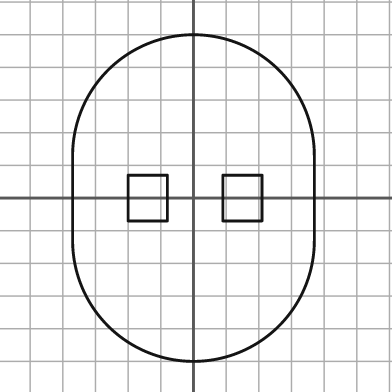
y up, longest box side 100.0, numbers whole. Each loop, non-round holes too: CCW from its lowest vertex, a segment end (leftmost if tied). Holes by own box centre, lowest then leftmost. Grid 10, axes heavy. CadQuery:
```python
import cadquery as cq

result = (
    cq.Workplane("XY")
    .moveTo(-37.0, -13.0)
    .threePointArc((0.0, -50.0), (37.0, -13.0))
    .lineTo(37.0, 13.0)
    .threePointArc((0.0, 50.0), (-37.0, 13.0))
    .close()
    .moveTo(-20.0, -7.0)
    .lineTo(-8.0, -7.0)
    .lineTo(-8.0, 7.0)
    .lineTo(-20.0, 7.0)
    .close()
    .moveTo(9.0, -7.0)
    .lineTo(21.0, -7.0)
    .lineTo(21.0, 7.0)
    .lineTo(9.0, 7.0)
    .close()
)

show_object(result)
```